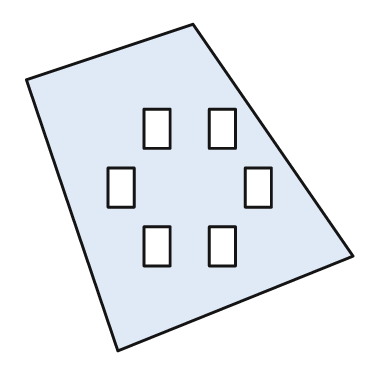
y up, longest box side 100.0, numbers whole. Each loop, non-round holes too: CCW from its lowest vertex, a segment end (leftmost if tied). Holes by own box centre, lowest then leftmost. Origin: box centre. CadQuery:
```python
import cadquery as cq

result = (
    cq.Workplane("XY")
    .moveTo(-22.0, -50.0)
    .lineTo(50.0, -21.0)
    .lineTo(1.0, 50.0)
    .lineTo(-50.0, 33.0)
    .close()
    .moveTo(-14.0, -24.0)
    .lineTo(-6.0, -24.0)
    .lineTo(-6.0, -12.0)
    .lineTo(-14.0, -12.0)
    .close()
    .moveTo(6.0, -24.0)
    .lineTo(14.0, -24.0)
    .lineTo(14.0, -12.0)
    .lineTo(6.0, -12.0)
    .close()
    .moveTo(-25.0, -6.0)
    .lineTo(-17.0, -6.0)
    .lineTo(-17.0, 6.0)
    .lineTo(-25.0, 6.0)
    .close()
    .moveTo(17.0, -6.0)
    .lineTo(25.0, -6.0)
    .lineTo(25.0, 6.0)
    .lineTo(17.0, 6.0)
    .close()
    .moveTo(-14.0, 12.0)
    .lineTo(-6.0, 12.0)
    .lineTo(-6.0, 24.0)
    .lineTo(-14.0, 24.0)
    .close()
    .moveTo(6.0, 12.0)
    .lineTo(14.0, 12.0)
    .lineTo(14.0, 24.0)
    .lineTo(6.0, 24.0)
    .close()
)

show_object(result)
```